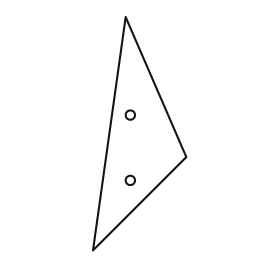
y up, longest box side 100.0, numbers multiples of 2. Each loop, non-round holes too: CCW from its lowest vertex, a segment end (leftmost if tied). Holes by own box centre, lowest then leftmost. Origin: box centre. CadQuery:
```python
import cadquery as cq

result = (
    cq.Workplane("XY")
    .moveTo(-20.0, -50.0)
    .lineTo(20.0, -10.0)
    .lineTo(-6.0, 50.0)
    .close()
    .moveTo(-4.0, -20.0)
    .circle(2.0)
    .moveTo(-4.0, 8.0)
    .circle(2.0)
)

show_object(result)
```